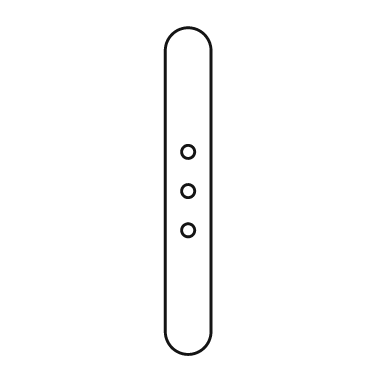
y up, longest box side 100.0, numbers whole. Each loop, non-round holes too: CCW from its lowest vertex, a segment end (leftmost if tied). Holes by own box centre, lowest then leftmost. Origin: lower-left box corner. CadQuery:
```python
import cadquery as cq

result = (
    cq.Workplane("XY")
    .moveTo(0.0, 7.0)
    .threePointArc((7.0, 0.0), (14.0, 7.0))
    .lineTo(14.0, 93.0)
    .threePointArc((7.0, 100.0), (0.0, 93.0))
    .close()
    .moveTo(7.0, 38.0)
    .circle(2.0)
    .moveTo(7.0, 50.0)
    .circle(2.0)
    .moveTo(7.0, 62.0)
    .circle(2.0)
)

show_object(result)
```